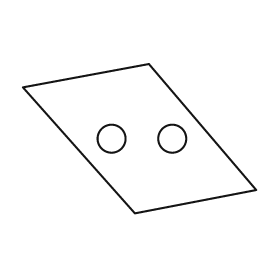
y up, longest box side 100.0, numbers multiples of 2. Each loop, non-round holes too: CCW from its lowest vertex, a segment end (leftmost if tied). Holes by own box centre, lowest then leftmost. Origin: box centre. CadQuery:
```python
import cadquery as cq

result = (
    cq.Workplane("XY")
    .moveTo(-2.0, -32.0)
    .lineTo(50.0, -22.0)
    .lineTo(4.0, 32.0)
    .lineTo(-50.0, 22.0)
    .close()
    .moveTo(-12.0, 0.0)
    .circle(6.0)
    .moveTo(14.0, 0.0)
    .circle(6.0)
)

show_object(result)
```